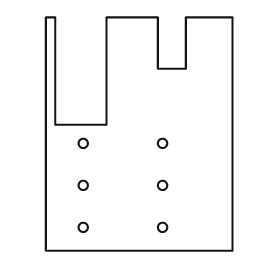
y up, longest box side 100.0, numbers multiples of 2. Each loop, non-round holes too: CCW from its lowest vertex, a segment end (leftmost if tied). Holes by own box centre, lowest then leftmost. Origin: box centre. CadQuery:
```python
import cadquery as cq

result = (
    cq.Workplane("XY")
    .moveTo(-40.0, -50.0)
    .lineTo(40.0, -50.0)
    .lineTo(40.0, 50.0)
    .lineTo(20.0, 50.0)
    .lineTo(20.0, 28.0)
    .lineTo(8.0, 28.0)
    .lineTo(8.0, 50.0)
    .lineTo(-14.0, 50.0)
    .lineTo(-14.0, 4.0)
    .lineTo(-36.0, 4.0)
    .lineTo(-36.0, 50.0)
    .lineTo(-40.0, 50.0)
    .close()
    .moveTo(-24.0, -40.0)
    .circle(2.0)
    .moveTo(10.0, -40.0)
    .circle(2.0)
    .moveTo(-24.0, -22.0)
    .circle(2.0)
    .moveTo(10.0, -22.0)
    .circle(2.0)
    .moveTo(-24.0, -4.0)
    .circle(2.0)
    .moveTo(10.0, -4.0)
    .circle(2.0)
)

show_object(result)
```